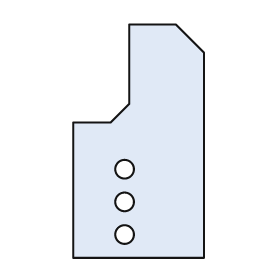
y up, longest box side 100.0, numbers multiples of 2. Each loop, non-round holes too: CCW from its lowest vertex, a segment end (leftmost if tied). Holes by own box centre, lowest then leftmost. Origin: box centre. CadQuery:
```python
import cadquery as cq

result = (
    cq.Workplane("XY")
    .moveTo(-28.0, -50.0)
    .lineTo(28.0, -50.0)
    .lineTo(28.0, 38.0)
    .lineTo(16.0, 50.0)
    .lineTo(-4.0, 50.0)
    .lineTo(-4.0, 16.0)
    .lineTo(-12.0, 8.0)
    .lineTo(-28.0, 8.0)
    .close()
    .moveTo(-6.0, -40.0)
    .circle(4.0)
    .moveTo(-6.0, -26.0)
    .circle(4.0)
    .moveTo(-6.0, -12.0)
    .circle(4.0)
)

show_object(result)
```